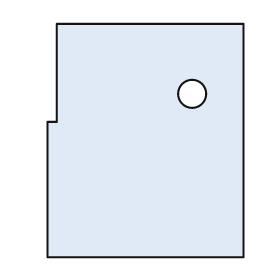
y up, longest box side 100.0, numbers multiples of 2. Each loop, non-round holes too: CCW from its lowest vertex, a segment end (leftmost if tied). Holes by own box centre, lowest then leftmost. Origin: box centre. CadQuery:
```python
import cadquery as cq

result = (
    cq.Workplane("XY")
    .moveTo(-42.0, -50.0)
    .lineTo(42.0, -50.0)
    .lineTo(42.0, 50.0)
    .lineTo(-38.0, 50.0)
    .lineTo(-38.0, 8.0)
    .lineTo(-42.0, 8.0)
    .close()
    .moveTo(20.0, 20.0)
    .circle(6.0)
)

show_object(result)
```